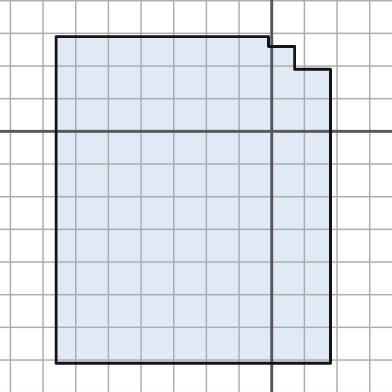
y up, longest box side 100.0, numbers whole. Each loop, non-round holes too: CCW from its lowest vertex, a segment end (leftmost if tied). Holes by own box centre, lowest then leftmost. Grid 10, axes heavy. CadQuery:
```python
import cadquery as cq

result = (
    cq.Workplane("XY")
    .moveTo(-66.0, -71.0)
    .lineTo(18.0, -71.0)
    .lineTo(18.0, 19.0)
    .lineTo(7.0, 19.0)
    .lineTo(7.0, 26.0)
    .lineTo(-1.0, 26.0)
    .lineTo(-1.0, 29.0)
    .lineTo(-66.0, 29.0)
    .close()
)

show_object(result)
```